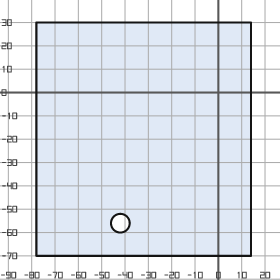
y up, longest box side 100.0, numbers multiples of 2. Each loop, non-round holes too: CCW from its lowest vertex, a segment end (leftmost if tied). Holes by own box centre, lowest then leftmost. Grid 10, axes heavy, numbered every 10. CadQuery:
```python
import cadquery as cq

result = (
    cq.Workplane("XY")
    .moveTo(-78.0, -70.0)
    .lineTo(14.0, -70.0)
    .lineTo(14.0, 30.0)
    .lineTo(-78.0, 30.0)
    .close()
    .moveTo(-42.0, -56.0)
    .circle(4.0)
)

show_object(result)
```